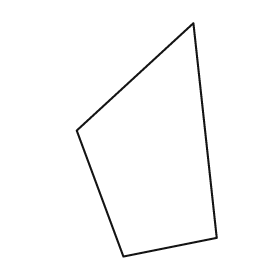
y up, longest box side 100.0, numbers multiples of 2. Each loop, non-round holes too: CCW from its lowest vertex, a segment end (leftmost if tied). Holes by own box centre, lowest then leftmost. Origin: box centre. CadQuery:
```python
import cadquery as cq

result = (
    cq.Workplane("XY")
    .moveTo(-10.0, -50.0)
    .lineTo(30.0, -42.0)
    .lineTo(20.0, 50.0)
    .lineTo(-30.0, 4.0)
    .close()
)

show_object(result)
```